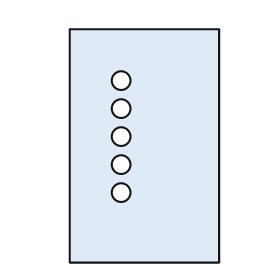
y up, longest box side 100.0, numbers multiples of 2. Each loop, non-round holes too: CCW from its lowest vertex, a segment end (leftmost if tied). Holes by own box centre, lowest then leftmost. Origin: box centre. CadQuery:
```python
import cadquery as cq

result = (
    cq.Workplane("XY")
    .moveTo(-32.0, -50.0)
    .lineTo(32.0, -50.0)
    .lineTo(32.0, 50.0)
    .lineTo(-32.0, 50.0)
    .close()
    .moveTo(-10.0, -20.0)
    .circle(4.0)
    .moveTo(-10.0, -8.0)
    .circle(4.0)
    .moveTo(-10.0, 4.0)
    .circle(4.0)
    .moveTo(-10.0, 16.0)
    .circle(4.0)
    .moveTo(-10.0, 28.0)
    .circle(4.0)
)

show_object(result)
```